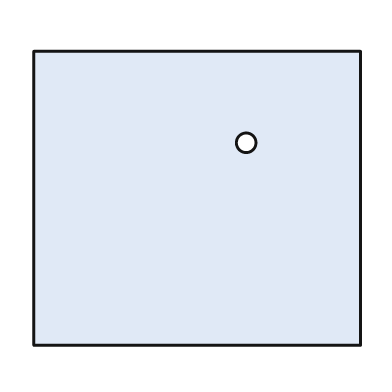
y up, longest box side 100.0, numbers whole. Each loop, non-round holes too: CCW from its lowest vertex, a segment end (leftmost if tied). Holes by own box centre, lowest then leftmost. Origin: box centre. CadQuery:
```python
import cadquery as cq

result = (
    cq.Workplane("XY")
    .moveTo(-50.0, -45.0)
    .lineTo(50.0, -45.0)
    .lineTo(50.0, 45.0)
    .lineTo(-50.0, 45.0)
    .close()
    .moveTo(15.0, 17.0)
    .circle(3.0)
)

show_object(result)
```